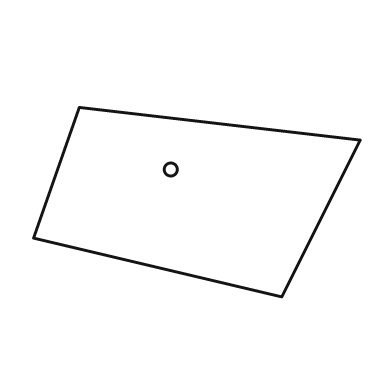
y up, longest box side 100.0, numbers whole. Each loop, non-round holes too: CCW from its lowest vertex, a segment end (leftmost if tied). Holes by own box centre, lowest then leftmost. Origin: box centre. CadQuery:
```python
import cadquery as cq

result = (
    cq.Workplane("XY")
    .moveTo(26.0, -29.0)
    .lineTo(50.0, 19.0)
    .lineTo(-36.0, 29.0)
    .lineTo(-50.0, -11.0)
    .close()
    .moveTo(-8.0, 10.0)
    .circle(2.0)
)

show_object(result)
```